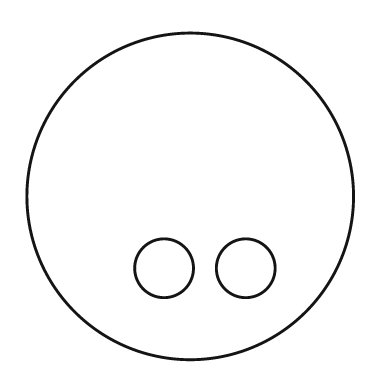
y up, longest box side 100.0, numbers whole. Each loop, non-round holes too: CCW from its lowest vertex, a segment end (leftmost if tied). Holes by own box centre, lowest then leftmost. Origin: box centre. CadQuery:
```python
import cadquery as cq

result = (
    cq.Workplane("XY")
    .moveTo(0.0, 0.0)
    .circle(50.0)
    .moveTo(-8.0, -22.0)
    .circle(9.0)
    .moveTo(17.0, -22.0)
    .circle(9.0)
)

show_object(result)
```